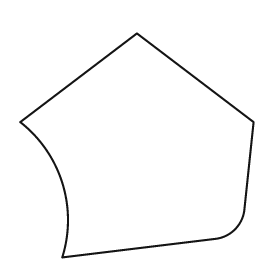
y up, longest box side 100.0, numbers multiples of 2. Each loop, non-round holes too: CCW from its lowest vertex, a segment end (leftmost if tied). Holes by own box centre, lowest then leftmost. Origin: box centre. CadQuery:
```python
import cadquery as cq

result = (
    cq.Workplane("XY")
    .moveTo(-32.0, -48.0)
    .lineTo(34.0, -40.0)
    .threePointArc((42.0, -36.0), (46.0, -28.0))
    .lineTo(50.0, 10.0)
    .lineTo(0.0, 48.0)
    .lineTo(-50.0, 10.0)
    .threePointArc((-32.0, -16.0), (-32.0, -48.0))
    .close()
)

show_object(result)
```